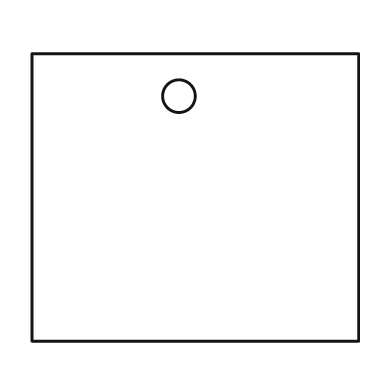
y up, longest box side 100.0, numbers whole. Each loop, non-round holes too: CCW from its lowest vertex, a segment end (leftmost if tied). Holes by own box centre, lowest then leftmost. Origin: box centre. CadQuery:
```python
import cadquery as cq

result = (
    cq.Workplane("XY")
    .moveTo(-50.0, -44.0)
    .lineTo(50.0, -44.0)
    .lineTo(50.0, 44.0)
    .lineTo(-50.0, 44.0)
    .close()
    .moveTo(-5.0, 31.0)
    .circle(5.0)
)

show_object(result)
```